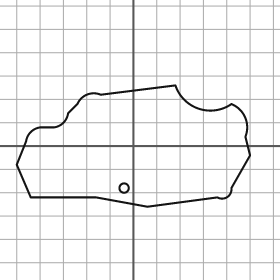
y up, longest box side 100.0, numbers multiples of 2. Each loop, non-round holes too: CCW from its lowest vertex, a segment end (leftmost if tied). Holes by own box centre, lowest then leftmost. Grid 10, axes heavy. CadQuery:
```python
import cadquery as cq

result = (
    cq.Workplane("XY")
    .moveTo(6.0, -26.0)
    .lineTo(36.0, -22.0)
    .threePointArc((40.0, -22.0), (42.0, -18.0))
    .lineTo(50.0, -4.0)
    .lineTo(48.0, 4.0)
    .threePointArc((48.0, 12.0), (42.0, 18.0))
    .threePointArc((28.0, 16.0), (18.0, 26.0))
    .lineTo(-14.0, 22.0)
    .threePointArc((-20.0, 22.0), (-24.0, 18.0))
    .lineTo(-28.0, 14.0)
    .threePointArc((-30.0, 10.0), (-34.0, 8.0))
    .lineTo(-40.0, 8.0)
    .threePointArc((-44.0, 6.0), (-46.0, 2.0))
    .lineTo(-50.0, -8.0)
    .lineTo(-44.0, -22.0)
    .lineTo(-16.0, -22.0)
    .close()
    .moveTo(-4.0, -18.0)
    .circle(2.0)
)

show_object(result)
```